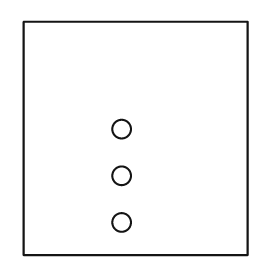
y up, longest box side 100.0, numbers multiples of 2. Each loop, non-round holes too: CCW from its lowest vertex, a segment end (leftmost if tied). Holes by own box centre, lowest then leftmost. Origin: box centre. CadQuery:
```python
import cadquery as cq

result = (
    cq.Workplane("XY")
    .moveTo(-48.0, -50.0)
    .lineTo(48.0, -50.0)
    .lineTo(48.0, 50.0)
    .lineTo(-48.0, 50.0)
    .close()
    .moveTo(-6.0, -36.0)
    .circle(4.0)
    .moveTo(-6.0, -16.0)
    .circle(4.0)
    .moveTo(-6.0, 4.0)
    .circle(4.0)
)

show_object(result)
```